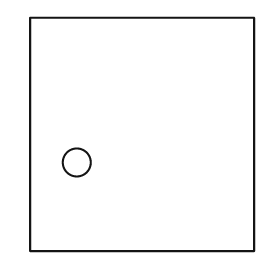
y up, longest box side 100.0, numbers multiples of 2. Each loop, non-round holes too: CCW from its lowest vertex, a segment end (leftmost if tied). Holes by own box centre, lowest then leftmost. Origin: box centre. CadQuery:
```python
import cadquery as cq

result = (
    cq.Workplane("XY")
    .moveTo(-48.0, -50.0)
    .lineTo(48.0, -50.0)
    .lineTo(48.0, 50.0)
    .lineTo(-48.0, 50.0)
    .close()
    .moveTo(-28.0, -12.0)
    .circle(6.0)
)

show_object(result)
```